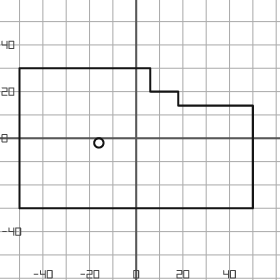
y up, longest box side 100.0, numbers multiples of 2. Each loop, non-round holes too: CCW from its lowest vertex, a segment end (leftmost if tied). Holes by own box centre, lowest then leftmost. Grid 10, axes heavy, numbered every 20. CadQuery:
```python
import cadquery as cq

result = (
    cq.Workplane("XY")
    .moveTo(-50.0, -30.0)
    .lineTo(50.0, -30.0)
    .lineTo(50.0, 14.0)
    .lineTo(18.0, 14.0)
    .lineTo(18.0, 20.0)
    .lineTo(6.0, 20.0)
    .lineTo(6.0, 30.0)
    .lineTo(-50.0, 30.0)
    .close()
    .moveTo(-16.0, -2.0)
    .circle(2.0)
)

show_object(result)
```